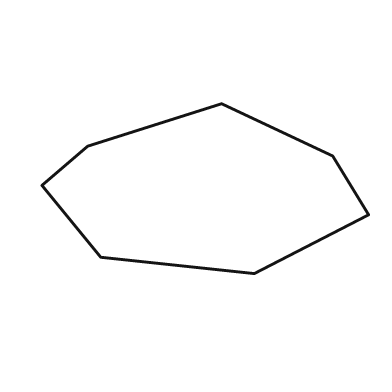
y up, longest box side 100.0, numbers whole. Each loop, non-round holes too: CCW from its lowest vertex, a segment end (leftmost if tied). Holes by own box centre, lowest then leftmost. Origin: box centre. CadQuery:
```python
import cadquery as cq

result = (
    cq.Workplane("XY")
    .moveTo(15.0, -26.0)
    .lineTo(50.0, -8.0)
    .lineTo(39.0, 10.0)
    .lineTo(5.0, 26.0)
    .lineTo(-36.0, 13.0)
    .lineTo(-50.0, 1.0)
    .lineTo(-32.0, -21.0)
    .close()
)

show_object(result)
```